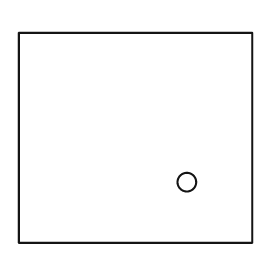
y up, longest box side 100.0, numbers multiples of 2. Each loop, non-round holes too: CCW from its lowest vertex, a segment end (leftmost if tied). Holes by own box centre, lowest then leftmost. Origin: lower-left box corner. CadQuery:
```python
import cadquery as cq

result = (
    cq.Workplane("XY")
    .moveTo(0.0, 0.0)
    .lineTo(100.0, 0.0)
    .lineTo(100.0, 90.0)
    .lineTo(0.0, 90.0)
    .close()
    .moveTo(72.0, 26.0)
    .circle(4.0)
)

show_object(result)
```